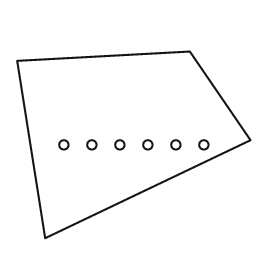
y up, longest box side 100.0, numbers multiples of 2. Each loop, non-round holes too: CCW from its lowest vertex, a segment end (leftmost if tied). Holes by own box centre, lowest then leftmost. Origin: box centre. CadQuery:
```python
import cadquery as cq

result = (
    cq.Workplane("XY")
    .moveTo(-38.0, -40.0)
    .lineTo(50.0, 2.0)
    .lineTo(24.0, 40.0)
    .lineTo(-50.0, 36.0)
    .close()
    .moveTo(-30.0, 0.0)
    .circle(2.0)
    .moveTo(-18.0, 0.0)
    .circle(2.0)
    .moveTo(-6.0, 0.0)
    .circle(2.0)
    .moveTo(6.0, 0.0)
    .circle(2.0)
    .moveTo(18.0, 0.0)
    .circle(2.0)
    .moveTo(30.0, 0.0)
    .circle(2.0)
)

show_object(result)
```